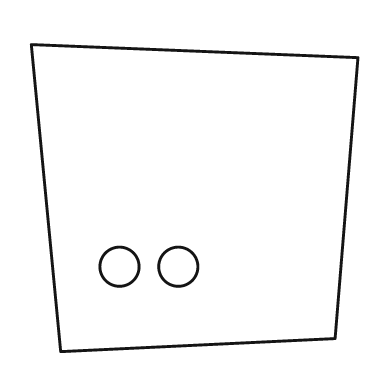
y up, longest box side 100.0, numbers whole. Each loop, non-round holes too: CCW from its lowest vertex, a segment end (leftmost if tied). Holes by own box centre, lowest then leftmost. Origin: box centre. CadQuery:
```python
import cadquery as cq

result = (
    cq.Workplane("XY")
    .moveTo(-41.0, -47.0)
    .lineTo(43.0, -43.0)
    .lineTo(50.0, 43.0)
    .lineTo(-50.0, 47.0)
    .close()
    .moveTo(-23.0, -21.0)
    .circle(6.0)
    .moveTo(-5.0, -21.0)
    .circle(6.0)
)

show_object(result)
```